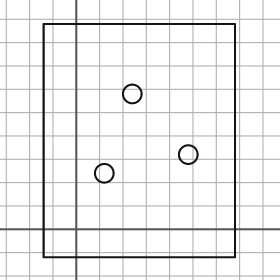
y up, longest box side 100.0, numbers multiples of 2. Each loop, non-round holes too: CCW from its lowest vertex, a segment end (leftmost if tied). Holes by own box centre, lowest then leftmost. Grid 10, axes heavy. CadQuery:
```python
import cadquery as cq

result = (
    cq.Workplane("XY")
    .moveTo(-14.0, -12.0)
    .lineTo(68.0, -12.0)
    .lineTo(68.0, 88.0)
    .lineTo(-14.0, 88.0)
    .close()
    .moveTo(12.0, 24.0)
    .circle(4.0)
    .moveTo(48.0, 32.0)
    .circle(4.0)
    .moveTo(24.0, 58.0)
    .circle(4.0)
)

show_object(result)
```